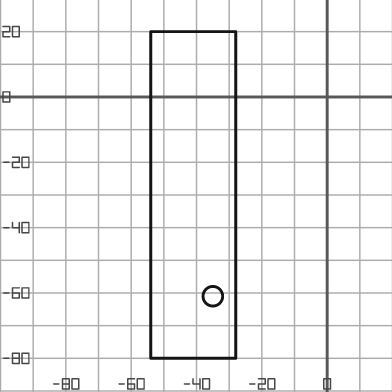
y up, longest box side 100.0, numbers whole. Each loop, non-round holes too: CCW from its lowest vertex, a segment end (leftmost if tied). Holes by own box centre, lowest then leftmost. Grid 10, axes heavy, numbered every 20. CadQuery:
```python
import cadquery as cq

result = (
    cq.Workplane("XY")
    .moveTo(-54.0, -80.0)
    .lineTo(-28.0, -80.0)
    .lineTo(-28.0, 20.0)
    .lineTo(-54.0, 20.0)
    .close()
    .moveTo(-35.0, -61.0)
    .circle(3.0)
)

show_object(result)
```